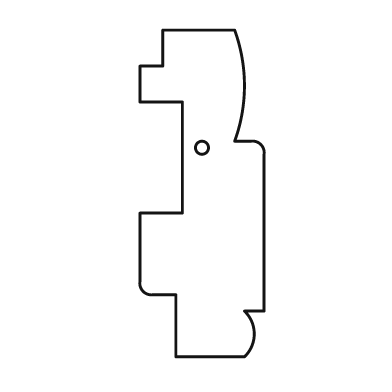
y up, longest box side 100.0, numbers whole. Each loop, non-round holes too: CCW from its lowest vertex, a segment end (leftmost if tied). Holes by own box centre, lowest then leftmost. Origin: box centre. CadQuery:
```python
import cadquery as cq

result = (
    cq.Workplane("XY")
    .moveTo(-8.0, -50.0)
    .lineTo(13.0, -50.0)
    .threePointArc((16.0, -43.0), (13.0, -36.0))
    .lineTo(19.0, -36.0)
    .lineTo(19.0, 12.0)
    .threePointArc((18.0, 15.0), (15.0, 16.0))
    .lineTo(10.0, 16.0)
    .threePointArc((13.0, 33.0), (10.0, 50.0))
    .lineTo(-12.0, 50.0)
    .lineTo(-12.0, 39.0)
    .lineTo(-19.0, 39.0)
    .lineTo(-19.0, 28.0)
    .lineTo(-6.0, 28.0)
    .lineTo(-6.0, -6.0)
    .lineTo(-19.0, -6.0)
    .lineTo(-19.0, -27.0)
    .threePointArc((-18.0, -30.0), (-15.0, -31.0))
    .lineTo(-8.0, -31.0)
    .close()
    .moveTo(0.0, 14.0)
    .circle(2.0)
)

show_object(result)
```